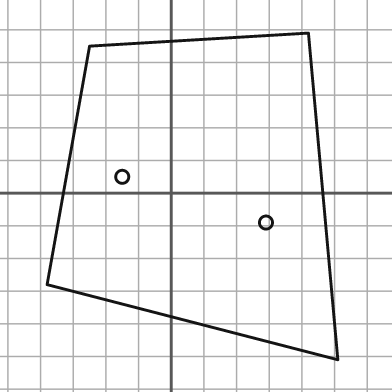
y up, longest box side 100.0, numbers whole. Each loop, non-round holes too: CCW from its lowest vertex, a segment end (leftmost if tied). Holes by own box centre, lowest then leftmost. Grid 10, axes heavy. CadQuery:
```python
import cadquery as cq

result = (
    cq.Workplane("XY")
    .moveTo(51.0, -51.0)
    .lineTo(42.0, 49.0)
    .lineTo(-25.0, 45.0)
    .lineTo(-38.0, -28.0)
    .close()
    .moveTo(29.0, -9.0)
    .circle(2.0)
    .moveTo(-15.0, 5.0)
    .circle(2.0)
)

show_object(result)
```